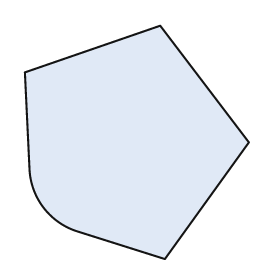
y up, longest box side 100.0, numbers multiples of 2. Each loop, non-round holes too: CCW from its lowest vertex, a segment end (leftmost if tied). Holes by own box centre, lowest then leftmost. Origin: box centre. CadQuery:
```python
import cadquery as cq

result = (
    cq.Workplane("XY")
    .moveTo(12.0, -50.0)
    .lineTo(48.0, 0.0)
    .lineTo(10.0, 50.0)
    .lineTo(-48.0, 30.0)
    .lineTo(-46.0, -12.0)
    .threePointArc((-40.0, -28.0), (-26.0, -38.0))
    .close()
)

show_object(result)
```